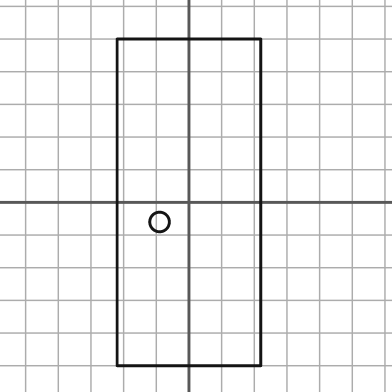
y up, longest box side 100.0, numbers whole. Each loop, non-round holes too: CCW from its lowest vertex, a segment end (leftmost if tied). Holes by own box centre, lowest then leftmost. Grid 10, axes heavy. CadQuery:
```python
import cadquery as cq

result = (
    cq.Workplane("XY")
    .moveTo(-22.0, -50.0)
    .lineTo(22.0, -50.0)
    .lineTo(22.0, 50.0)
    .lineTo(-22.0, 50.0)
    .close()
    .moveTo(-9.0, -6.0)
    .circle(3.0)
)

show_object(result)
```